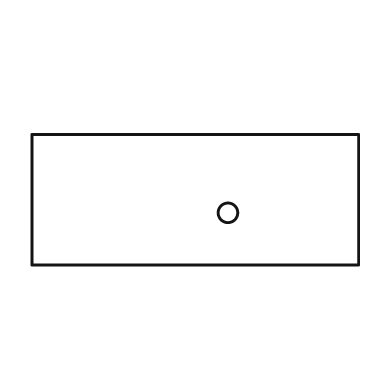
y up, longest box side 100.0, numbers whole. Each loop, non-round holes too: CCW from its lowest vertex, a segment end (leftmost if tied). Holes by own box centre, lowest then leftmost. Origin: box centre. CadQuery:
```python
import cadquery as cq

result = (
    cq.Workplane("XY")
    .moveTo(-50.0, -20.0)
    .lineTo(50.0, -20.0)
    .lineTo(50.0, 20.0)
    .lineTo(-50.0, 20.0)
    .close()
    .moveTo(10.0, -4.0)
    .circle(3.0)
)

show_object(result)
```